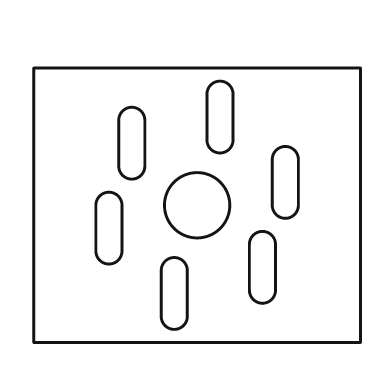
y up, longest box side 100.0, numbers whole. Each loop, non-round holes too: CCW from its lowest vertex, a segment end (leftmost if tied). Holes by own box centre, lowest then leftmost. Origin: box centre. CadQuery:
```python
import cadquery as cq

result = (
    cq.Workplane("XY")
    .moveTo(-50.0, -42.0)
    .lineTo(50.0, -42.0)
    .lineTo(50.0, 42.0)
    .lineTo(-50.0, 42.0)
    .close()
    .moveTo(-11.0, -34.0)
    .threePointArc((-7.0, -38.0), (-3.0, -34.0))
    .lineTo(-3.0, -20.0)
    .threePointArc((-7.0, -16.0), (-11.0, -20.0))
    .close()
    .moveTo(16.0, -26.0)
    .threePointArc((20.0, -30.0), (24.0, -26.0))
    .lineTo(24.0, -12.0)
    .threePointArc((20.0, -8.0), (16.0, -12.0))
    .close()
    .moveTo(-31.0, -14.0)
    .threePointArc((-27.0, -18.0), (-23.0, -14.0))
    .lineTo(-23.0, 0.0)
    .threePointArc((-27.0, 4.0), (-31.0, 0.0))
    .close()
    .moveTo(0.0, 0.0)
    .circle(10.0)
    .moveTo(23.0, 0.0)
    .threePointArc((27.0, -4.0), (31.0, 0.0))
    .lineTo(31.0, 14.0)
    .threePointArc((27.0, 18.0), (23.0, 14.0))
    .close()
    .moveTo(-24.0, 12.0)
    .threePointArc((-20.0, 8.0), (-16.0, 12.0))
    .lineTo(-16.0, 26.0)
    .threePointArc((-20.0, 30.0), (-24.0, 26.0))
    .close()
    .moveTo(3.0, 20.0)
    .threePointArc((7.0, 16.0), (11.0, 20.0))
    .lineTo(11.0, 34.0)
    .threePointArc((7.0, 38.0), (3.0, 34.0))
    .close()
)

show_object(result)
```